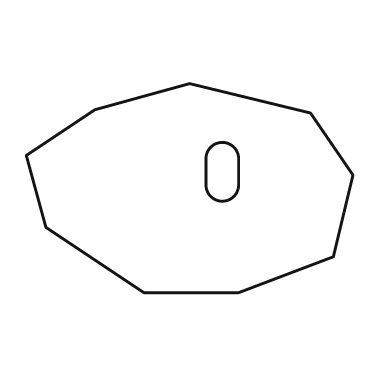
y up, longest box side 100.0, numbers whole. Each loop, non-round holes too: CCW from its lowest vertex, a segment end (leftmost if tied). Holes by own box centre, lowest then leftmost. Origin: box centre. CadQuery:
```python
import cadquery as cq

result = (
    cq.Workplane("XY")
    .moveTo(-14.0, -32.0)
    .lineTo(15.0, -32.0)
    .lineTo(44.0, -21.0)
    .lineTo(50.0, 4.0)
    .lineTo(37.0, 23.0)
    .lineTo(0.0, 32.0)
    .lineTo(-29.0, 24.0)
    .lineTo(-50.0, 10.0)
    .lineTo(-44.0, -12.0)
    .close()
    .moveTo(5.0, 1.0)
    .threePointArc((10.0, -4.0), (15.0, 1.0))
    .lineTo(15.0, 9.0)
    .threePointArc((10.0, 14.0), (5.0, 9.0))
    .close()
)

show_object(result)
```